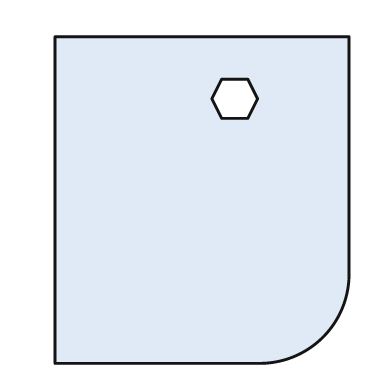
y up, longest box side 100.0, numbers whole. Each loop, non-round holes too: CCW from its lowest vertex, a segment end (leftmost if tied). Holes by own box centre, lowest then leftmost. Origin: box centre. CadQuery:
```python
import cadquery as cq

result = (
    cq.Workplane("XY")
    .moveTo(-45.0, -50.0)
    .lineTo(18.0, -50.0)
    .threePointArc((37.0, -42.0), (45.0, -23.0))
    .lineTo(45.0, 50.0)
    .lineTo(-45.0, 50.0)
    .close()
    .moveTo(6.0, 25.0)
    .lineTo(14.0, 25.0)
    .lineTo(17.0, 31.0)
    .lineTo(14.0, 37.0)
    .lineTo(6.0, 37.0)
    .lineTo(3.0, 31.0)
    .close()
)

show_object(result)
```